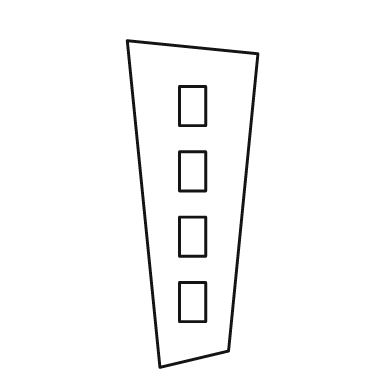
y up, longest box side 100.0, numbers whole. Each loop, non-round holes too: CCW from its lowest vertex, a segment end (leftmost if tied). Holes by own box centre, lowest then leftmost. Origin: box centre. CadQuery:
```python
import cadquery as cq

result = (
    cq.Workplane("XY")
    .moveTo(-10.0, -50.0)
    .lineTo(11.0, -45.0)
    .lineTo(20.0, 46.0)
    .lineTo(-20.0, 50.0)
    .close()
    .moveTo(-4.0, -36.0)
    .lineTo(4.0, -36.0)
    .lineTo(4.0, -24.0)
    .lineTo(-4.0, -24.0)
    .close()
    .moveTo(-4.0, -16.0)
    .lineTo(4.0, -16.0)
    .lineTo(4.0, -4.0)
    .lineTo(-4.0, -4.0)
    .close()
    .moveTo(-4.0, 4.0)
    .lineTo(4.0, 4.0)
    .lineTo(4.0, 16.0)
    .lineTo(-4.0, 16.0)
    .close()
    .moveTo(-4.0, 24.0)
    .lineTo(4.0, 24.0)
    .lineTo(4.0, 36.0)
    .lineTo(-4.0, 36.0)
    .close()
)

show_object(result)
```